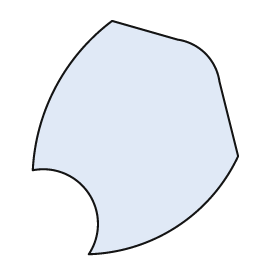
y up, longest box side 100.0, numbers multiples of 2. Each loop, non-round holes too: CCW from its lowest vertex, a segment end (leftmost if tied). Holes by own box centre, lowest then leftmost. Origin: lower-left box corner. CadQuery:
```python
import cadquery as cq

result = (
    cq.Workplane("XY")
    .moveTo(24.0, 0.0)
    .threePointArc((62.0, 12.0), (88.0, 42.0))
    .lineTo(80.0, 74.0)
    .threePointArc((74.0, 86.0), (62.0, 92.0))
    .lineTo(34.0, 100.0)
    .threePointArc((10.0, 72.0), (0.0, 36.0))
    .threePointArc((24.0, 26.0), (24.0, 0.0))
    .close()
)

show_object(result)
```